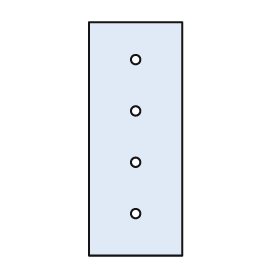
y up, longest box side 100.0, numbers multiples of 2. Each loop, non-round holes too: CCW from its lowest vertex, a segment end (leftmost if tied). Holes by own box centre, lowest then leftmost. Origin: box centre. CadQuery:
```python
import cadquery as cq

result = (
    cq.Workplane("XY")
    .moveTo(-20.0, -50.0)
    .lineTo(20.0, -50.0)
    .lineTo(20.0, 50.0)
    .lineTo(-20.0, 50.0)
    .close()
    .moveTo(0.0, -32.0)
    .circle(2.0)
    .moveTo(0.0, -10.0)
    .circle(2.0)
    .moveTo(0.0, 12.0)
    .circle(2.0)
    .moveTo(0.0, 34.0)
    .circle(2.0)
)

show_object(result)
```